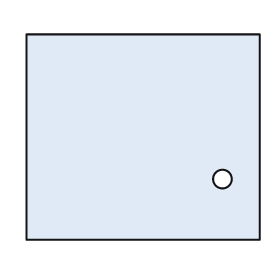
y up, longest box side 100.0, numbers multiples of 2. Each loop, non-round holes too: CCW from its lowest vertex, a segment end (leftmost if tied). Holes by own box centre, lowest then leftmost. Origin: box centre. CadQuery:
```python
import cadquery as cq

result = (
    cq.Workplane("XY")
    .moveTo(-50.0, -44.0)
    .lineTo(50.0, -44.0)
    .lineTo(50.0, 44.0)
    .lineTo(-50.0, 44.0)
    .close()
    .moveTo(34.0, -18.0)
    .circle(4.0)
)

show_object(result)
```